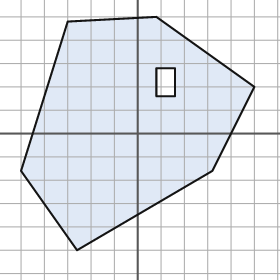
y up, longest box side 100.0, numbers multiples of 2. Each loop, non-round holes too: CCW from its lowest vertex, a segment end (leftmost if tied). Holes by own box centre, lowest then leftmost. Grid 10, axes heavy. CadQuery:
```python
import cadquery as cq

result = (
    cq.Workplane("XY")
    .moveTo(-26.0, -50.0)
    .lineTo(32.0, -16.0)
    .lineTo(50.0, 20.0)
    .lineTo(8.0, 50.0)
    .lineTo(-30.0, 48.0)
    .lineTo(-50.0, -16.0)
    .close()
    .moveTo(8.0, 16.0)
    .lineTo(16.0, 16.0)
    .lineTo(16.0, 28.0)
    .lineTo(8.0, 28.0)
    .close()
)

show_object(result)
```